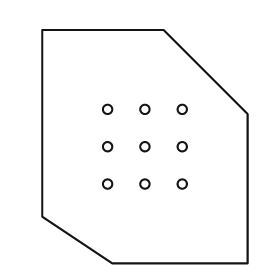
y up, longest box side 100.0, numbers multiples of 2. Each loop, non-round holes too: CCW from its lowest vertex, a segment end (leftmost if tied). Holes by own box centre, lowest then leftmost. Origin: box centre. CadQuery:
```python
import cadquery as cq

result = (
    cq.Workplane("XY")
    .moveTo(-14.0, -50.0)
    .lineTo(44.0, -50.0)
    .lineTo(44.0, 14.0)
    .lineTo(8.0, 50.0)
    .lineTo(-44.0, 50.0)
    .lineTo(-44.0, -30.0)
    .close()
    .moveTo(-16.0, -16.0)
    .circle(2.0)
    .moveTo(0.0, -16.0)
    .circle(2.0)
    .moveTo(16.0, -16.0)
    .circle(2.0)
    .moveTo(-16.0, 0.0)
    .circle(2.0)
    .moveTo(0.0, 0.0)
    .circle(2.0)
    .moveTo(16.0, 0.0)
    .circle(2.0)
    .moveTo(-16.0, 16.0)
    .circle(2.0)
    .moveTo(0.0, 16.0)
    .circle(2.0)
    .moveTo(16.0, 16.0)
    .circle(2.0)
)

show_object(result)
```